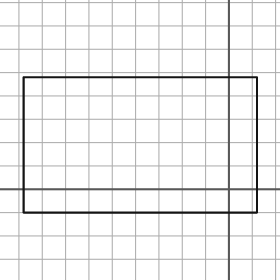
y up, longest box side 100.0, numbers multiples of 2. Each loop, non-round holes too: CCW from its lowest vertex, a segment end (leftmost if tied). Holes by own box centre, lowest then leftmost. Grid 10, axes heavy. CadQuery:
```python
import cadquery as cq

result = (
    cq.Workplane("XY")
    .moveTo(-88.0, -10.0)
    .lineTo(12.0, -10.0)
    .lineTo(12.0, 48.0)
    .lineTo(-88.0, 48.0)
    .close()
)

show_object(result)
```